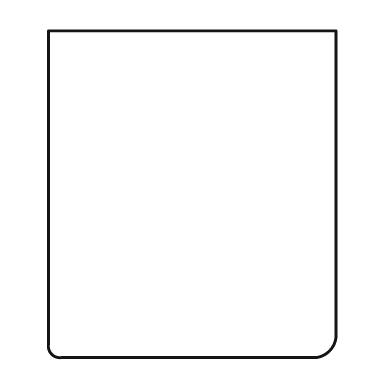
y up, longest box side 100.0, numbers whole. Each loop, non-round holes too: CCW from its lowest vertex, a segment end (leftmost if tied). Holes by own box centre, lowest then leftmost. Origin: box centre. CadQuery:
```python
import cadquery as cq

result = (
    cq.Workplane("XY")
    .moveTo(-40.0, -50.0)
    .lineTo(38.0, -50.0)
    .threePointArc((42.0, -48.0), (44.0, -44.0))
    .lineTo(44.0, 50.0)
    .lineTo(-44.0, 50.0)
    .lineTo(-44.0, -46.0)
    .threePointArc((-43.0, -49.0), (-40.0, -50.0))
    .close()
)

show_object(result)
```